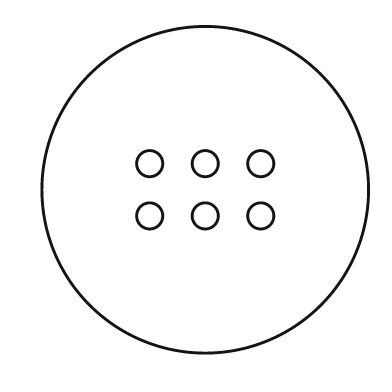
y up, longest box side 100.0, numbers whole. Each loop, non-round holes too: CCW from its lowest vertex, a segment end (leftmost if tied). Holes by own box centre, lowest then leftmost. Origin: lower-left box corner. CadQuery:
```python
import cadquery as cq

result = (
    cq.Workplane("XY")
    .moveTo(50.0, 50.0)
    .circle(50.0)
    .moveTo(33.0, 42.0)
    .circle(4.0)
    .moveTo(50.0, 42.0)
    .circle(4.0)
    .moveTo(67.0, 42.0)
    .circle(4.0)
    .moveTo(33.0, 58.0)
    .circle(4.0)
    .moveTo(50.0, 58.0)
    .circle(4.0)
    .moveTo(67.0, 58.0)
    .circle(4.0)
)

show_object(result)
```